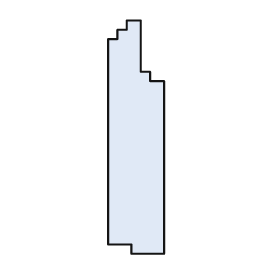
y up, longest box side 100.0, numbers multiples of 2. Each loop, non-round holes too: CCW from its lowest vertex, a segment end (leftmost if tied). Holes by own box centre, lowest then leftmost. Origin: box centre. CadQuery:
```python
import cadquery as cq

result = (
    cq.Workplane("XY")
    .moveTo(-2.0, -50.0)
    .lineTo(12.0, -50.0)
    .lineTo(12.0, 24.0)
    .lineTo(6.0, 24.0)
    .lineTo(6.0, 28.0)
    .lineTo(2.0, 28.0)
    .lineTo(2.0, 50.0)
    .lineTo(-4.0, 50.0)
    .lineTo(-4.0, 46.0)
    .lineTo(-8.0, 46.0)
    .lineTo(-8.0, 42.0)
    .lineTo(-12.0, 42.0)
    .lineTo(-12.0, -46.0)
    .lineTo(-2.0, -46.0)
    .close()
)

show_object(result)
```